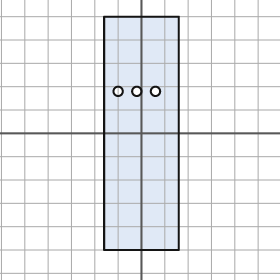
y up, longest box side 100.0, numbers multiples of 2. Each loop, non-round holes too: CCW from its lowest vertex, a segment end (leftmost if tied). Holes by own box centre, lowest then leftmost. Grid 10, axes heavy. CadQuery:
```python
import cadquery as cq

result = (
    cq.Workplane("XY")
    .moveTo(-16.0, -50.0)
    .lineTo(16.0, -50.0)
    .lineTo(16.0, 50.0)
    .lineTo(-16.0, 50.0)
    .close()
    .moveTo(-10.0, 18.0)
    .circle(2.0)
    .moveTo(-2.0, 18.0)
    .circle(2.0)
    .moveTo(6.0, 18.0)
    .circle(2.0)
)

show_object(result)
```